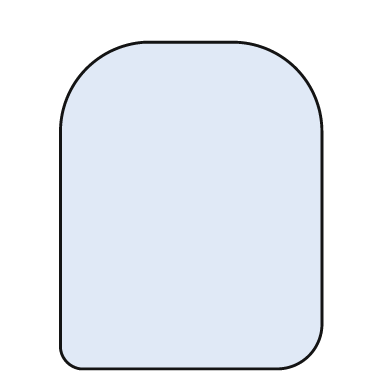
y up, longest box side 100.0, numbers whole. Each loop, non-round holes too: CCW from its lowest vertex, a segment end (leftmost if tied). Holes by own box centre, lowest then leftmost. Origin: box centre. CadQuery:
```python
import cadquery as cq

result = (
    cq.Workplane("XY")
    .moveTo(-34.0, -50.0)
    .lineTo(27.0, -50.0)
    .threePointArc((36.0, -46.0), (40.0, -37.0))
    .lineTo(40.0, 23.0)
    .threePointArc((32.0, 42.0), (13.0, 50.0))
    .lineTo(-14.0, 50.0)
    .threePointArc((-32.0, 42.0), (-40.0, 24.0))
    .lineTo(-40.0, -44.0)
    .threePointArc((-38.0, -48.0), (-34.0, -50.0))
    .close()
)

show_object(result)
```